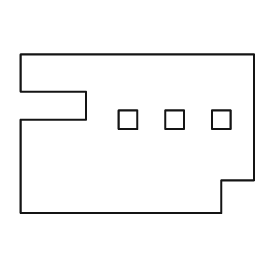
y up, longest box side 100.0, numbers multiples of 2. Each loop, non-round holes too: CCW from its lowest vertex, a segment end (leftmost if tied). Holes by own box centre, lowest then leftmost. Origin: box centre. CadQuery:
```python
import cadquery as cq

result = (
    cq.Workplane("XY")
    .moveTo(-50.0, -34.0)
    .lineTo(36.0, -34.0)
    .lineTo(36.0, -20.0)
    .lineTo(50.0, -20.0)
    .lineTo(50.0, 34.0)
    .lineTo(-50.0, 34.0)
    .lineTo(-50.0, 18.0)
    .lineTo(-22.0, 18.0)
    .lineTo(-22.0, 6.0)
    .lineTo(-50.0, 6.0)
    .close()
    .moveTo(-8.0, 2.0)
    .lineTo(0.0, 2.0)
    .lineTo(0.0, 10.0)
    .lineTo(-8.0, 10.0)
    .close()
    .moveTo(12.0, 2.0)
    .lineTo(20.0, 2.0)
    .lineTo(20.0, 10.0)
    .lineTo(12.0, 10.0)
    .close()
    .moveTo(32.0, 2.0)
    .lineTo(40.0, 2.0)
    .lineTo(40.0, 10.0)
    .lineTo(32.0, 10.0)
    .close()
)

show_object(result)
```